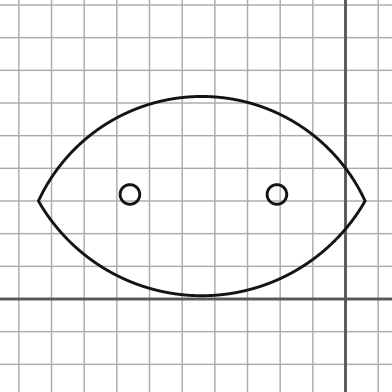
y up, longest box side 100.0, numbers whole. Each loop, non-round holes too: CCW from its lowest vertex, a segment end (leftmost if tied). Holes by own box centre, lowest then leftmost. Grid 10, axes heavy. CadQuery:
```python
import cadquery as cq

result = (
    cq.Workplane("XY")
    .moveTo(-94.0, 30.0)
    .threePointArc((-44.0, 1.0), (6.0, 30.0))
    .threePointArc((-44.0, 62.0), (-94.0, 30.0))
    .close()
    .moveTo(-66.0, 32.0)
    .circle(3.0)
    .moveTo(-21.0, 32.0)
    .circle(3.0)
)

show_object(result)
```